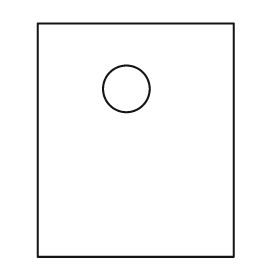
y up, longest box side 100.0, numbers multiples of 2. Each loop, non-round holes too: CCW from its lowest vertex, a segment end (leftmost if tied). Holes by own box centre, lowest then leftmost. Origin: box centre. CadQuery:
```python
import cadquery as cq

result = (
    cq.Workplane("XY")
    .moveTo(-42.0, -50.0)
    .lineTo(42.0, -50.0)
    .lineTo(42.0, 50.0)
    .lineTo(-42.0, 50.0)
    .close()
    .moveTo(-4.0, 22.0)
    .circle(10.0)
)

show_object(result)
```